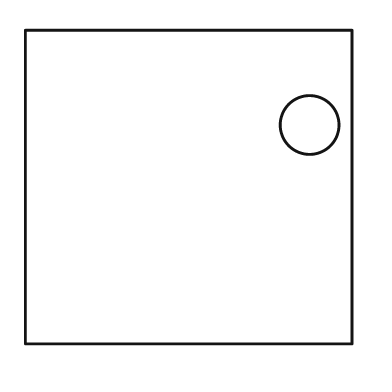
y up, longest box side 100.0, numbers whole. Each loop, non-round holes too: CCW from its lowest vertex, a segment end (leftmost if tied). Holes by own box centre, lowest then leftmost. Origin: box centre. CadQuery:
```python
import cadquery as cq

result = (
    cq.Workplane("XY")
    .moveTo(-50.0, -48.0)
    .lineTo(50.0, -48.0)
    .lineTo(50.0, 48.0)
    .lineTo(-50.0, 48.0)
    .close()
    .moveTo(37.0, 19.0)
    .circle(9.0)
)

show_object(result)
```